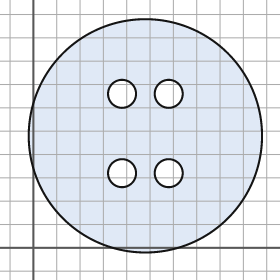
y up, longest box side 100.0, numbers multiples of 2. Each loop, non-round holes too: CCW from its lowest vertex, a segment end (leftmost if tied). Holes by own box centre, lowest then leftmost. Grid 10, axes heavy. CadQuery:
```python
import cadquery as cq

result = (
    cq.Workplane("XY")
    .moveTo(48.0, 48.0)
    .circle(50.0)
    .moveTo(38.0, 32.0)
    .circle(6.0)
    .moveTo(58.0, 32.0)
    .circle(6.0)
    .moveTo(38.0, 66.0)
    .circle(6.0)
    .moveTo(58.0, 66.0)
    .circle(6.0)
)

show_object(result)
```